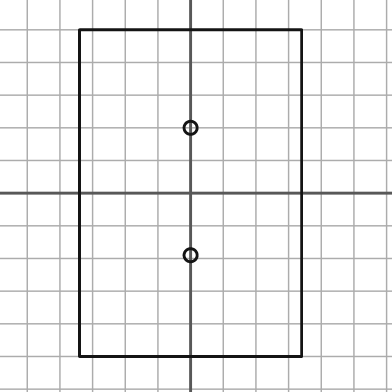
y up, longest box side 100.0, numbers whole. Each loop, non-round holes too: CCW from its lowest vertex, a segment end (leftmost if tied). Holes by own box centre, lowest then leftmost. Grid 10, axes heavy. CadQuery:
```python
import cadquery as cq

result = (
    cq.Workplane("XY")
    .moveTo(-34.0, -50.0)
    .lineTo(34.0, -50.0)
    .lineTo(34.0, 50.0)
    .lineTo(-34.0, 50.0)
    .close()
    .moveTo(0.0, -19.0)
    .circle(2.0)
    .moveTo(0.0, 20.0)
    .circle(2.0)
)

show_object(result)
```